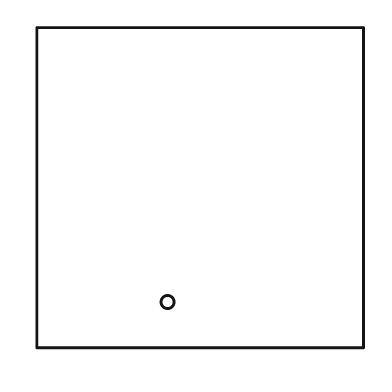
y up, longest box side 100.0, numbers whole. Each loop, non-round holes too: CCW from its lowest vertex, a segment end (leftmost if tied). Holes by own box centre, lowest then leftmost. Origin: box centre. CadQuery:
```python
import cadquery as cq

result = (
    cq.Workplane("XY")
    .moveTo(-50.0, -49.0)
    .lineTo(50.0, -49.0)
    .lineTo(50.0, 49.0)
    .lineTo(-50.0, 49.0)
    .close()
    .moveTo(-10.0, -35.0)
    .circle(2.0)
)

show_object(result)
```